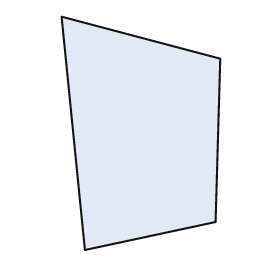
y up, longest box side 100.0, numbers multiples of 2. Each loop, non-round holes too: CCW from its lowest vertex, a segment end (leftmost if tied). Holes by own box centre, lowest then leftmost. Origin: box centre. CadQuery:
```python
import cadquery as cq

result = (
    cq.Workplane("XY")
    .moveTo(-24.0, -50.0)
    .lineTo(32.0, -38.0)
    .lineTo(34.0, 32.0)
    .lineTo(-34.0, 50.0)
    .close()
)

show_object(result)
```